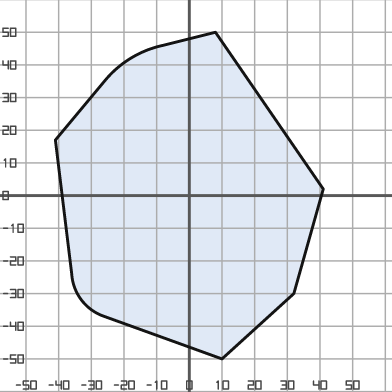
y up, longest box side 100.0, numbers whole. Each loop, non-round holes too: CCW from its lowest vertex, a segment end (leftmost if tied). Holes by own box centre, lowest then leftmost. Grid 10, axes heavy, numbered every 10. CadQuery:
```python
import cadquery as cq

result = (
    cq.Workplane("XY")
    .moveTo(10.0, -50.0)
    .lineTo(32.0, -30.0)
    .lineTo(41.0, 2.0)
    .lineTo(8.0, 50.0)
    .lineTo(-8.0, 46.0)
    .threePointArc((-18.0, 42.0), (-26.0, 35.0))
    .lineTo(-41.0, 17.0)
    .lineTo(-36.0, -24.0)
    .threePointArc((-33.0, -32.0), (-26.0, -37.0))
    .close()
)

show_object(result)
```